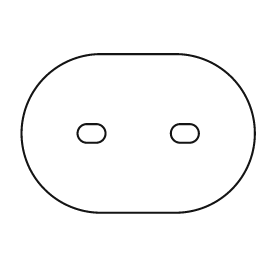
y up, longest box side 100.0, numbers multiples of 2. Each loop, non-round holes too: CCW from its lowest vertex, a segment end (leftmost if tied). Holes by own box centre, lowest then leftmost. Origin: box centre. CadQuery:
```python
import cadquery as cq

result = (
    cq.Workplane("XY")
    .moveTo(-16.0, -34.0)
    .lineTo(16.0, -34.0)
    .threePointArc((50.0, 0.0), (16.0, 34.0))
    .lineTo(-16.0, 34.0)
    .threePointArc((-50.0, 0.0), (-16.0, -34.0))
    .close()
    .moveTo(-22.0, -4.0)
    .lineTo(-18.0, -4.0)
    .threePointArc((-14.0, 0.0), (-18.0, 4.0))
    .lineTo(-22.0, 4.0)
    .threePointArc((-26.0, 0.0), (-22.0, -4.0))
    .close()
    .moveTo(18.0, -4.0)
    .lineTo(22.0, -4.0)
    .threePointArc((26.0, 0.0), (22.0, 4.0))
    .lineTo(18.0, 4.0)
    .threePointArc((14.0, 0.0), (18.0, -4.0))
    .close()
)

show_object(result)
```